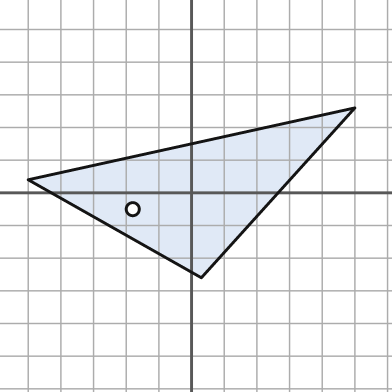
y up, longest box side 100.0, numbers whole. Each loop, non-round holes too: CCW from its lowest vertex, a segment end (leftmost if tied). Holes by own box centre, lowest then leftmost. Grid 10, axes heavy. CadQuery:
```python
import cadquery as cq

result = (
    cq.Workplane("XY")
    .moveTo(3.0, -26.0)
    .lineTo(50.0, 26.0)
    .lineTo(-50.0, 4.0)
    .close()
    .moveTo(-18.0, -5.0)
    .circle(2.0)
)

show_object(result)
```